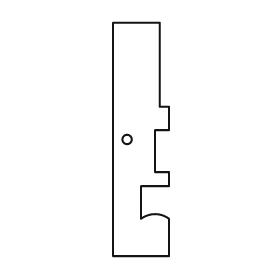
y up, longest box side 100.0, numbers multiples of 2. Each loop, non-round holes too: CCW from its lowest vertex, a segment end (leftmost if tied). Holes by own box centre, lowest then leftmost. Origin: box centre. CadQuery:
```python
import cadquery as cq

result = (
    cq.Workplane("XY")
    .moveTo(-12.0, -50.0)
    .lineTo(12.0, -50.0)
    .lineTo(12.0, -34.0)
    .threePointArc((6.0, -32.0), (0.0, -34.0))
    .lineTo(0.0, -20.0)
    .lineTo(12.0, -20.0)
    .lineTo(12.0, -14.0)
    .lineTo(6.0, -14.0)
    .lineTo(6.0, 4.0)
    .lineTo(12.0, 4.0)
    .lineTo(12.0, 14.0)
    .lineTo(8.0, 14.0)
    .lineTo(8.0, 50.0)
    .lineTo(-12.0, 50.0)
    .close()
    .moveTo(-6.0, 0.0)
    .circle(2.0)
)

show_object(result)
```